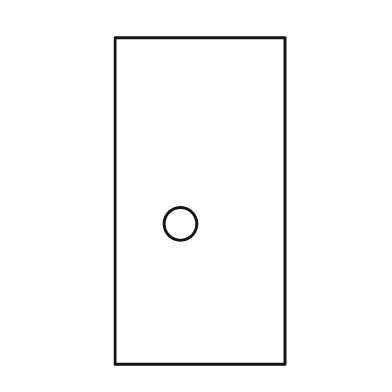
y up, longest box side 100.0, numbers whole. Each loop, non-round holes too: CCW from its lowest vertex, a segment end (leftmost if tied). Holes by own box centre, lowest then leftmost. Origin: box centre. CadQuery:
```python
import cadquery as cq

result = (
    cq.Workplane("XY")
    .moveTo(-26.0, -50.0)
    .lineTo(26.0, -50.0)
    .lineTo(26.0, 50.0)
    .lineTo(-26.0, 50.0)
    .close()
    .moveTo(-6.0, -7.0)
    .circle(5.0)
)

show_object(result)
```